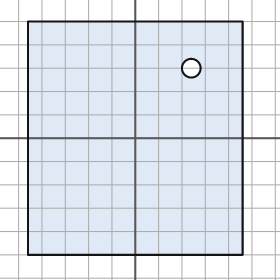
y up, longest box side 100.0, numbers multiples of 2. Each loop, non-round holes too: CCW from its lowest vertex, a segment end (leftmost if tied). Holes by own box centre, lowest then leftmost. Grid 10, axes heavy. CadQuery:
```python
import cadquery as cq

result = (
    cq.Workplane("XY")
    .moveTo(-46.0, -50.0)
    .lineTo(46.0, -50.0)
    .lineTo(46.0, 50.0)
    .lineTo(-46.0, 50.0)
    .close()
    .moveTo(24.0, 30.0)
    .circle(4.0)
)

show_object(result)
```